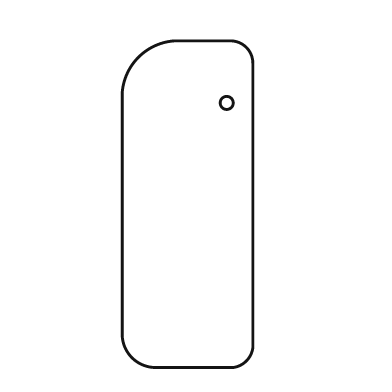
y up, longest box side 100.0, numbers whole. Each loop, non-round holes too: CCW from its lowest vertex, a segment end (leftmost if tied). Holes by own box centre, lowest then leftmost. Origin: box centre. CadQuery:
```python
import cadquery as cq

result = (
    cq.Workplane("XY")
    .moveTo(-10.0, -50.0)
    .lineTo(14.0, -50.0)
    .threePointArc((18.0, -48.0), (20.0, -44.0))
    .lineTo(20.0, 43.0)
    .threePointArc((18.0, 48.0), (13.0, 50.0))
    .lineTo(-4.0, 50.0)
    .threePointArc((-15.0, 45.0), (-20.0, 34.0))
    .lineTo(-20.0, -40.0)
    .threePointArc((-17.0, -47.0), (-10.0, -50.0))
    .close()
    .moveTo(12.0, 31.0)
    .circle(2.0)
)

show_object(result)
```